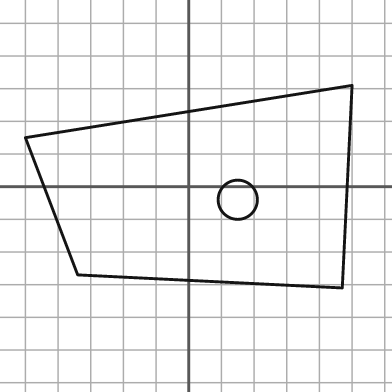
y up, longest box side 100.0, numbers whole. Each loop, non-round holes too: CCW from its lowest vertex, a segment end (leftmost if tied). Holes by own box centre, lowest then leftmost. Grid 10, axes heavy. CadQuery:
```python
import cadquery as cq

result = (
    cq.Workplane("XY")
    .moveTo(47.0, -31.0)
    .lineTo(50.0, 31.0)
    .lineTo(-50.0, 15.0)
    .lineTo(-34.0, -27.0)
    .close()
    .moveTo(15.0, -4.0)
    .circle(6.0)
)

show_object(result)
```